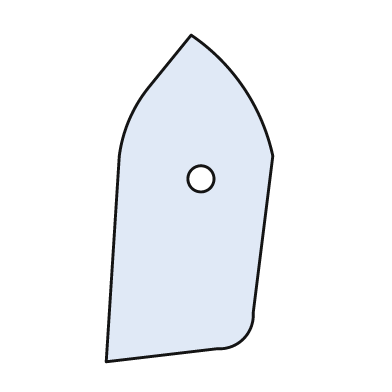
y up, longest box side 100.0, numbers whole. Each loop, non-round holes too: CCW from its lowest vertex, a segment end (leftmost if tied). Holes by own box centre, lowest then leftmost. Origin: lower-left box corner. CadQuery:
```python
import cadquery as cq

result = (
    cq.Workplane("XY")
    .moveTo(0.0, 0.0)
    .lineTo(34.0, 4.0)
    .threePointArc((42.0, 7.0), (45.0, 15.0))
    .lineTo(51.0, 63.0)
    .threePointArc((42.0, 84.0), (26.0, 100.0))
    .lineTo(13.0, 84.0)
    .threePointArc((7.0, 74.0), (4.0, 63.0))
    .close()
    .moveTo(29.0, 56.0)
    .circle(4.0)
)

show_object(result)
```